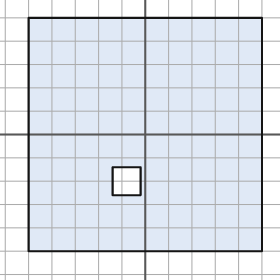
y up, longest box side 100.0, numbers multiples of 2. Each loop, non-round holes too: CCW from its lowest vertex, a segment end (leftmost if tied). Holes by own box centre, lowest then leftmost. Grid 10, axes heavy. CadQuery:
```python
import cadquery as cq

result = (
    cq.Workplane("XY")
    .moveTo(-50.0, -50.0)
    .lineTo(50.0, -50.0)
    .lineTo(50.0, 50.0)
    .lineTo(-50.0, 50.0)
    .close()
    .moveTo(-14.0, -26.0)
    .lineTo(-2.0, -26.0)
    .lineTo(-2.0, -14.0)
    .lineTo(-14.0, -14.0)
    .close()
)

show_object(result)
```